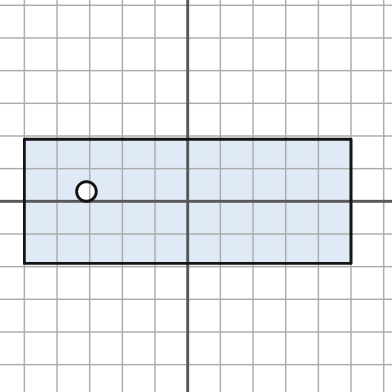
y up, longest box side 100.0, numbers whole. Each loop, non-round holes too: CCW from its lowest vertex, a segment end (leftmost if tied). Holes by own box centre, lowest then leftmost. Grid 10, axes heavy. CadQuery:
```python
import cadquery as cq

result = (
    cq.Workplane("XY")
    .moveTo(-50.0, -19.0)
    .lineTo(50.0, -19.0)
    .lineTo(50.0, 19.0)
    .lineTo(-50.0, 19.0)
    .close()
    .moveTo(-31.0, 3.0)
    .circle(3.0)
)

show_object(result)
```